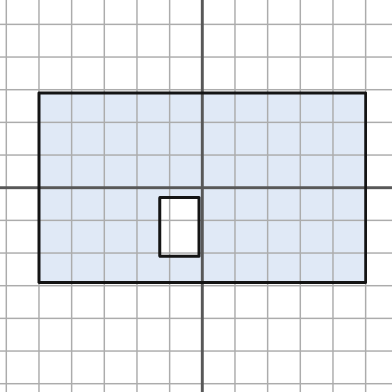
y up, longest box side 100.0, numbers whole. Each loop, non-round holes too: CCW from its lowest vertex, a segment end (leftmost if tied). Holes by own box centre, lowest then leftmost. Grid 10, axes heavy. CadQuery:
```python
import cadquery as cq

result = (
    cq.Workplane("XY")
    .moveTo(-50.0, -29.0)
    .lineTo(50.0, -29.0)
    .lineTo(50.0, 29.0)
    .lineTo(-50.0, 29.0)
    .close()
    .moveTo(-13.0, -21.0)
    .lineTo(-1.0, -21.0)
    .lineTo(-1.0, -3.0)
    .lineTo(-13.0, -3.0)
    .close()
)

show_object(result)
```